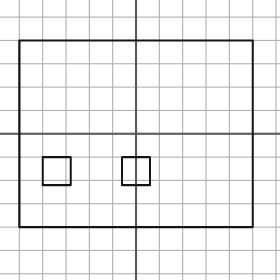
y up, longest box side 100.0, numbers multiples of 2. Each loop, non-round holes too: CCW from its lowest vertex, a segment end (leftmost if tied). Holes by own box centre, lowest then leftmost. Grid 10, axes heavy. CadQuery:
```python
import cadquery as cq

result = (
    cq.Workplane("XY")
    .moveTo(-50.0, -40.0)
    .lineTo(50.0, -40.0)
    .lineTo(50.0, 40.0)
    .lineTo(-50.0, 40.0)
    .close()
    .moveTo(-40.0, -22.0)
    .lineTo(-28.0, -22.0)
    .lineTo(-28.0, -10.0)
    .lineTo(-40.0, -10.0)
    .close()
    .moveTo(-6.0, -22.0)
    .lineTo(6.0, -22.0)
    .lineTo(6.0, -10.0)
    .lineTo(-6.0, -10.0)
    .close()
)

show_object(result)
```